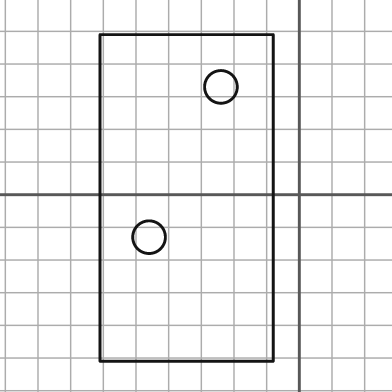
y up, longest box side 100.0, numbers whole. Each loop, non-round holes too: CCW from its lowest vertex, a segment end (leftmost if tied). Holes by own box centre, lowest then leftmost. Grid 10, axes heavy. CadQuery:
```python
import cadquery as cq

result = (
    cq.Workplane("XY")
    .moveTo(-61.0, -51.0)
    .lineTo(-8.0, -51.0)
    .lineTo(-8.0, 49.0)
    .lineTo(-61.0, 49.0)
    .close()
    .moveTo(-46.0, -13.0)
    .circle(5.0)
    .moveTo(-24.0, 33.0)
    .circle(5.0)
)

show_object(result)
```